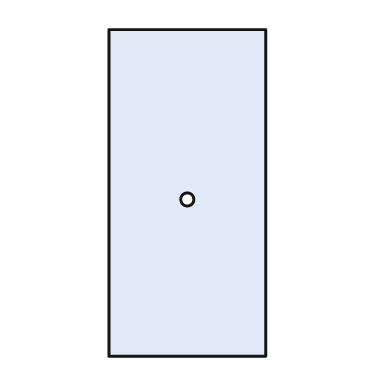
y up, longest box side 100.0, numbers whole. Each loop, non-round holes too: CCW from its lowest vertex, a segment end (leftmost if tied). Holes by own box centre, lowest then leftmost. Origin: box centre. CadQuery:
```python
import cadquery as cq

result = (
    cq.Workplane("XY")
    .moveTo(-24.0, -50.0)
    .lineTo(24.0, -50.0)
    .lineTo(24.0, 50.0)
    .lineTo(-24.0, 50.0)
    .close()
    .moveTo(0.0, -2.0)
    .circle(2.0)
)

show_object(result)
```